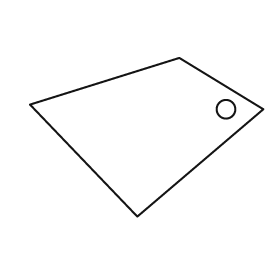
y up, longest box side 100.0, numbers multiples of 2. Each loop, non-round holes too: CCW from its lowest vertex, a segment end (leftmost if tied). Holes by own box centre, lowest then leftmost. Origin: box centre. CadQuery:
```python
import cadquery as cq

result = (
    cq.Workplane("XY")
    .moveTo(-4.0, -34.0)
    .lineTo(50.0, 12.0)
    .lineTo(14.0, 34.0)
    .lineTo(-50.0, 14.0)
    .close()
    .moveTo(34.0, 12.0)
    .circle(4.0)
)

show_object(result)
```